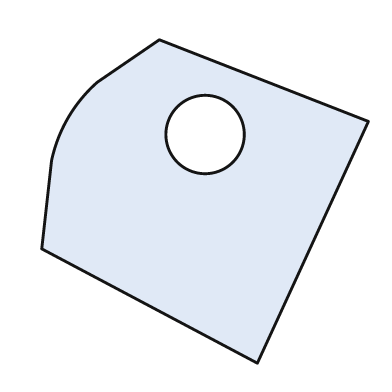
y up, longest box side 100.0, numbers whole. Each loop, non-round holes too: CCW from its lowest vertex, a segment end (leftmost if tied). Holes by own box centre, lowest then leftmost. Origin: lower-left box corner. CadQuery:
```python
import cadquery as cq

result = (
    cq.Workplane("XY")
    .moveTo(66.0, 0.0)
    .lineTo(100.0, 74.0)
    .lineTo(36.0, 99.0)
    .lineTo(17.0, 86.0)
    .threePointArc((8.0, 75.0), (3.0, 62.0))
    .lineTo(0.0, 35.0)
    .close()
    .moveTo(50.0, 70.0)
    .circle(12.0)
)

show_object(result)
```